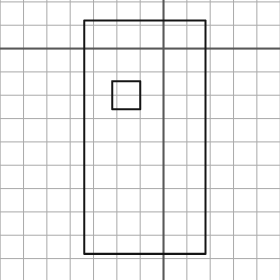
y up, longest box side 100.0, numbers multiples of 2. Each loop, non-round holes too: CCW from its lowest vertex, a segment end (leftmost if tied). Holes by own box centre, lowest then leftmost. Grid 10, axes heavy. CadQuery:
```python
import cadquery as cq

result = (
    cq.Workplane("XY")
    .moveTo(-34.0, -88.0)
    .lineTo(18.0, -88.0)
    .lineTo(18.0, 12.0)
    .lineTo(-34.0, 12.0)
    .close()
    .moveTo(-22.0, -26.0)
    .lineTo(-10.0, -26.0)
    .lineTo(-10.0, -14.0)
    .lineTo(-22.0, -14.0)
    .close()
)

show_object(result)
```